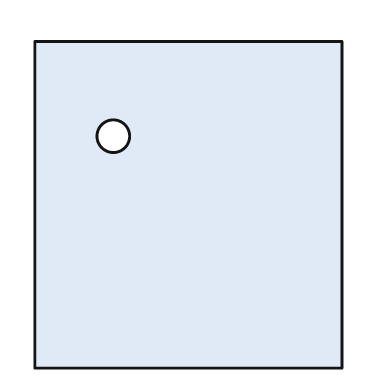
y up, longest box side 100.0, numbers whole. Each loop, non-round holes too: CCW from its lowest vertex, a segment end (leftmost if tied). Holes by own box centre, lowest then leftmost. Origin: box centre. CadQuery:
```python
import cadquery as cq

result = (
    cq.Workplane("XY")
    .moveTo(-47.0, -50.0)
    .lineTo(47.0, -50.0)
    .lineTo(47.0, 50.0)
    .lineTo(-47.0, 50.0)
    .close()
    .moveTo(-23.0, 21.0)
    .circle(5.0)
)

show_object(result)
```